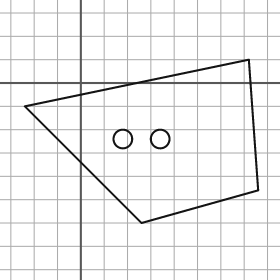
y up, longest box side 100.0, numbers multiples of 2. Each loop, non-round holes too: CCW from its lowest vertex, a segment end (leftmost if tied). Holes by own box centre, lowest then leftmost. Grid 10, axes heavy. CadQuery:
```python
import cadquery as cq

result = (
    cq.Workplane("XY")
    .moveTo(26.0, -60.0)
    .lineTo(76.0, -46.0)
    .lineTo(72.0, 10.0)
    .lineTo(-24.0, -10.0)
    .close()
    .moveTo(18.0, -24.0)
    .circle(4.0)
    .moveTo(34.0, -24.0)
    .circle(4.0)
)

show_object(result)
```